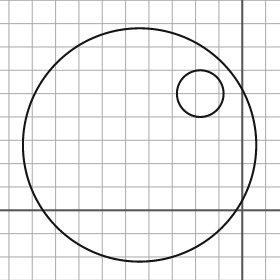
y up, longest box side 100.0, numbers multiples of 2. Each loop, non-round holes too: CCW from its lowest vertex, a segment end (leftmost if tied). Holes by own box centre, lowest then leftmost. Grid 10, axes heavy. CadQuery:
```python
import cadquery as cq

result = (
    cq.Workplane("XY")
    .moveTo(-44.0, 28.0)
    .circle(50.0)
    .moveTo(-18.0, 50.0)
    .circle(10.0)
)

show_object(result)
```